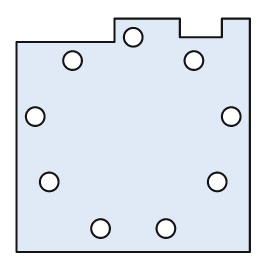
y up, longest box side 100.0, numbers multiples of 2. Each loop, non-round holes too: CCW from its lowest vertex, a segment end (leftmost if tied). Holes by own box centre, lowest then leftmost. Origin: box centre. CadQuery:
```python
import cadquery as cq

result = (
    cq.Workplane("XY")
    .moveTo(-50.0, -50.0)
    .lineTo(50.0, -50.0)
    .lineTo(50.0, 50.0)
    .lineTo(38.0, 50.0)
    .lineTo(38.0, 42.0)
    .lineTo(20.0, 42.0)
    .lineTo(20.0, 50.0)
    .lineTo(-8.0, 50.0)
    .lineTo(-8.0, 40.0)
    .lineTo(-50.0, 40.0)
    .close()
    .moveTo(-14.0, -40.0)
    .circle(4.0)
    .moveTo(14.0, -40.0)
    .circle(4.0)
    .moveTo(-36.0, -20.0)
    .circle(4.0)
    .moveTo(36.0, -20.0)
    .circle(4.0)
    .moveTo(-42.0, 8.0)
    .circle(4.0)
    .moveTo(42.0, 8.0)
    .circle(4.0)
    .moveTo(-26.0, 32.0)
    .circle(4.0)
    .moveTo(26.0, 32.0)
    .circle(4.0)
    .moveTo(0.0, 42.0)
    .circle(4.0)
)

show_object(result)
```